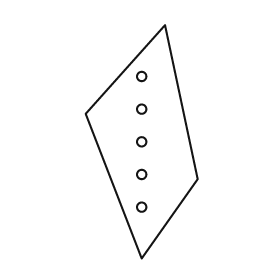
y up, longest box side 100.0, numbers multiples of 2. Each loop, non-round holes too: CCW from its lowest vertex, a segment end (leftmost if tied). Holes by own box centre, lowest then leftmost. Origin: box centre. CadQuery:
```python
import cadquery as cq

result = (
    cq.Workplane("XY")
    .moveTo(0.0, -50.0)
    .lineTo(24.0, -16.0)
    .lineTo(10.0, 50.0)
    .lineTo(-24.0, 12.0)
    .close()
    .moveTo(0.0, -28.0)
    .circle(2.0)
    .moveTo(0.0, -14.0)
    .circle(2.0)
    .moveTo(0.0, 0.0)
    .circle(2.0)
    .moveTo(0.0, 14.0)
    .circle(2.0)
    .moveTo(0.0, 28.0)
    .circle(2.0)
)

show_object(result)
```